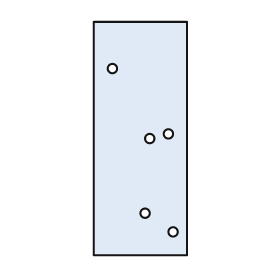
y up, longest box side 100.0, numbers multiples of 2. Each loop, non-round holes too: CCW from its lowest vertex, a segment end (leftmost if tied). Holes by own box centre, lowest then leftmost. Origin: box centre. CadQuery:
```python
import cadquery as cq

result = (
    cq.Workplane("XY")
    .moveTo(-20.0, -50.0)
    .lineTo(20.0, -50.0)
    .lineTo(20.0, 50.0)
    .lineTo(-20.0, 50.0)
    .close()
    .moveTo(14.0, -40.0)
    .circle(2.0)
    .moveTo(2.0, -32.0)
    .circle(2.0)
    .moveTo(4.0, 0.0)
    .circle(2.0)
    .moveTo(12.0, 2.0)
    .circle(2.0)
    .moveTo(-12.0, 30.0)
    .circle(2.0)
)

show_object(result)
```